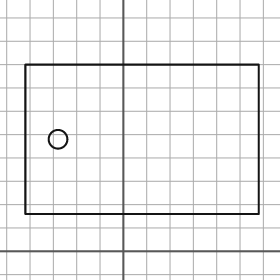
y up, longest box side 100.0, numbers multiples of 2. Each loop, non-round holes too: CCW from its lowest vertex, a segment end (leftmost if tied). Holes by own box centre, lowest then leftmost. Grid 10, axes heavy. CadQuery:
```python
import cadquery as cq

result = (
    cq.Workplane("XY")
    .moveTo(-42.0, 16.0)
    .lineTo(58.0, 16.0)
    .lineTo(58.0, 80.0)
    .lineTo(-42.0, 80.0)
    .close()
    .moveTo(-28.0, 48.0)
    .circle(4.0)
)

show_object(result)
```